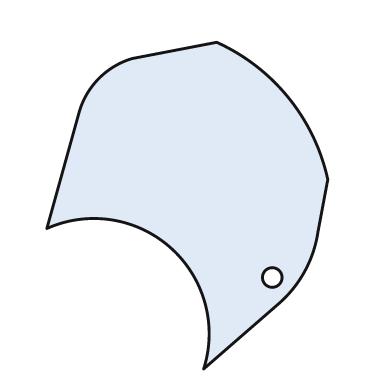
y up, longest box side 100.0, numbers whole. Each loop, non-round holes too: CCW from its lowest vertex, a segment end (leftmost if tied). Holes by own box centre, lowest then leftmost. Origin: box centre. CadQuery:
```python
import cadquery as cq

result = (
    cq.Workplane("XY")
    .moveTo(5.0, -50.0)
    .lineTo(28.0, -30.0)
    .threePointArc((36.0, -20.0), (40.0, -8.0))
    .lineTo(43.0, 8.0)
    .threePointArc((31.0, 33.0), (9.0, 50.0))
    .lineTo(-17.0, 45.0)
    .threePointArc((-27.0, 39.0), (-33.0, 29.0))
    .lineTo(-43.0, -7.0)
    .threePointArc((-5.0, -13.0), (5.0, -50.0))
    .close()
    .moveTo(26.0, -22.0)
    .circle(3.0)
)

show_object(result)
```